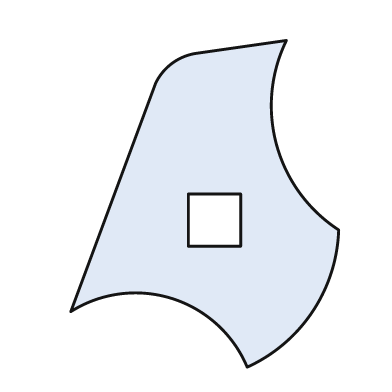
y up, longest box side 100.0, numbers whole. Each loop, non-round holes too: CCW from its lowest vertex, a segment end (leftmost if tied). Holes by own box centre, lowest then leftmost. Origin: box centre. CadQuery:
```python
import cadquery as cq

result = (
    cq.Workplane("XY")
    .moveTo(13.0, -50.0)
    .threePointArc((33.0, -33.0), (41.0, -8.0))
    .threePointArc((22.0, 18.0), (25.0, 50.0))
    .lineTo(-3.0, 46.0)
    .threePointArc((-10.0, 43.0), (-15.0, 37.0))
    .lineTo(-41.0, -33.0)
    .threePointArc((-10.0, -29.0), (13.0, -50.0))
    .close()
    .moveTo(-5.0, -13.0)
    .lineTo(11.0, -13.0)
    .lineTo(11.0, 3.0)
    .lineTo(-5.0, 3.0)
    .close()
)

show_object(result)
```